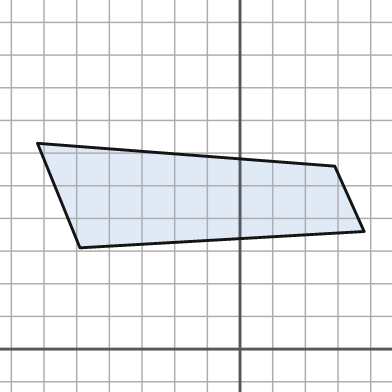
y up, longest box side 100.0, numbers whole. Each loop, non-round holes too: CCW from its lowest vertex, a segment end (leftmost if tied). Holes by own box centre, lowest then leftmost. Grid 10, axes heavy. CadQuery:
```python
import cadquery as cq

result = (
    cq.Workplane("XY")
    .moveTo(-49.0, 31.0)
    .lineTo(38.0, 36.0)
    .lineTo(29.0, 56.0)
    .lineTo(-62.0, 63.0)
    .close()
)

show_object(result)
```